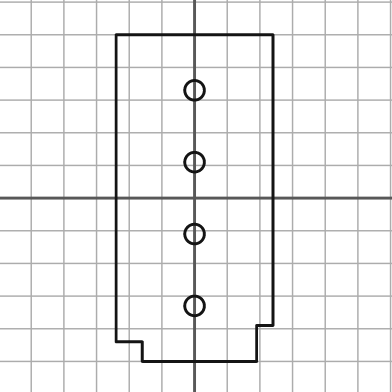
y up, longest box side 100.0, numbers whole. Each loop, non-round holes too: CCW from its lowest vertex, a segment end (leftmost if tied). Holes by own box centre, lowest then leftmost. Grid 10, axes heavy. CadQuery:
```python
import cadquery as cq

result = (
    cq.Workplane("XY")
    .moveTo(-16.0, -50.0)
    .lineTo(19.0, -50.0)
    .lineTo(19.0, -39.0)
    .lineTo(24.0, -39.0)
    .lineTo(24.0, 50.0)
    .lineTo(-24.0, 50.0)
    .lineTo(-24.0, -44.0)
    .lineTo(-16.0, -44.0)
    .close()
    .moveTo(0.0, -33.0)
    .circle(3.0)
    .moveTo(0.0, -11.0)
    .circle(3.0)
    .moveTo(0.0, 11.0)
    .circle(3.0)
    .moveTo(0.0, 33.0)
    .circle(3.0)
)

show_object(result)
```